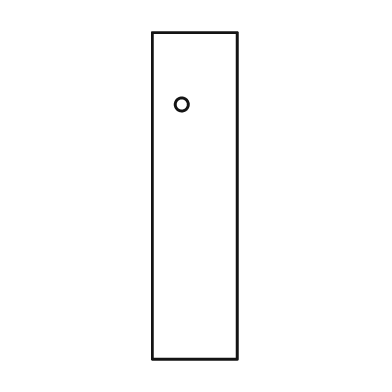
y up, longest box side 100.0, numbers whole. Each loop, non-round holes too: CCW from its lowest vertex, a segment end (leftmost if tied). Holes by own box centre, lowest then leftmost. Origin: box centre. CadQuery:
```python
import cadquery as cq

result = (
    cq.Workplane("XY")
    .moveTo(-13.0, -50.0)
    .lineTo(13.0, -50.0)
    .lineTo(13.0, 50.0)
    .lineTo(-13.0, 50.0)
    .close()
    .moveTo(-4.0, 28.0)
    .circle(2.0)
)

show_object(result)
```